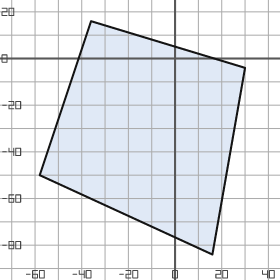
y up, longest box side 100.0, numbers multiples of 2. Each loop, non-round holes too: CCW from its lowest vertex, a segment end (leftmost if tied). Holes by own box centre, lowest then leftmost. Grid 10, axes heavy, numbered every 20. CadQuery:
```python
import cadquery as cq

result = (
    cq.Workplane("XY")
    .moveTo(16.0, -84.0)
    .lineTo(30.0, -4.0)
    .lineTo(-36.0, 16.0)
    .lineTo(-58.0, -50.0)
    .close()
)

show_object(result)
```